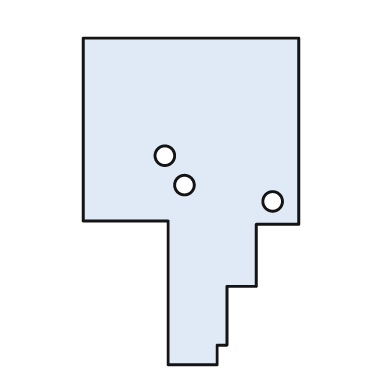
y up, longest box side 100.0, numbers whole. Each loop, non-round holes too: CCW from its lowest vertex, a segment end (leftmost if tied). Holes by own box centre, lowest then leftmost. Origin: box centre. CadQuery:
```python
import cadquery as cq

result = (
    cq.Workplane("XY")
    .moveTo(-7.0, -50.0)
    .lineTo(8.0, -50.0)
    .lineTo(8.0, -44.0)
    .lineTo(11.0, -44.0)
    .lineTo(11.0, -26.0)
    .lineTo(20.0, -26.0)
    .lineTo(20.0, -7.0)
    .lineTo(33.0, -7.0)
    .lineTo(33.0, 50.0)
    .lineTo(-33.0, 50.0)
    .lineTo(-33.0, -6.0)
    .lineTo(-7.0, -6.0)
    .close()
    .moveTo(25.0, 0.0)
    .circle(3.0)
    .moveTo(-2.0, 5.0)
    .circle(3.0)
    .moveTo(-8.0, 14.0)
    .circle(3.0)
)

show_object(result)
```